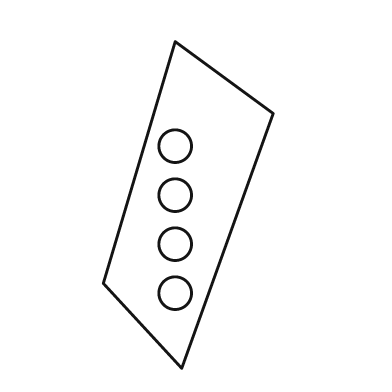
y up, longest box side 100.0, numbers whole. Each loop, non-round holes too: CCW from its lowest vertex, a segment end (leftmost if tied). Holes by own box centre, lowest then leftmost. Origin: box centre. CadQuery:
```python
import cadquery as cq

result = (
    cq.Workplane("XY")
    .moveTo(-2.0, -50.0)
    .lineTo(26.0, 28.0)
    .lineTo(-4.0, 50.0)
    .lineTo(-26.0, -24.0)
    .close()
    .moveTo(-4.0, -27.0)
    .circle(5.0)
    .moveTo(-4.0, -12.0)
    .circle(5.0)
    .moveTo(-4.0, 3.0)
    .circle(5.0)
    .moveTo(-4.0, 18.0)
    .circle(5.0)
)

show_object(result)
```